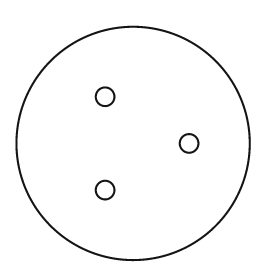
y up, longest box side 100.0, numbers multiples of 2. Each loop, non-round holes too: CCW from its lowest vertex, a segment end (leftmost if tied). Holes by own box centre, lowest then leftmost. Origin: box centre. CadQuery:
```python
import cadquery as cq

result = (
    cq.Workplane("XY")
    .moveTo(0.0, 0.0)
    .circle(50.0)
    .moveTo(-12.0, -20.0)
    .circle(4.0)
    .moveTo(24.0, 0.0)
    .circle(4.0)
    .moveTo(-12.0, 20.0)
    .circle(4.0)
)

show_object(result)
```